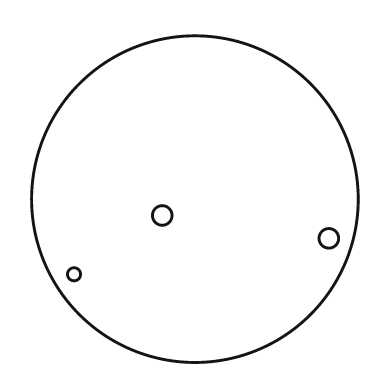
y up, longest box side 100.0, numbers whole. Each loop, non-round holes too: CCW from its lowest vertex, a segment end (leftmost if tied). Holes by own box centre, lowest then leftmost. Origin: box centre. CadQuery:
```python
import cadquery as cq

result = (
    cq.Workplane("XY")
    .moveTo(0.0, 0.0)
    .circle(50.0)
    .moveTo(-37.0, -23.0)
    .circle(2.0)
    .moveTo(41.0, -12.0)
    .circle(3.0)
    .moveTo(-10.0, -5.0)
    .circle(3.0)
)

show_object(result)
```